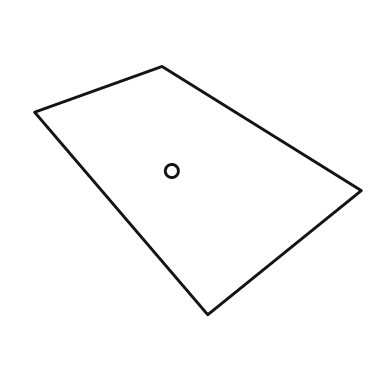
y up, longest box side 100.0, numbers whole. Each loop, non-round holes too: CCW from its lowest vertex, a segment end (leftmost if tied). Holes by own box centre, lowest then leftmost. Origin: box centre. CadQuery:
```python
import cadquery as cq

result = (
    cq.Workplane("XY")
    .moveTo(3.0, -38.0)
    .lineTo(50.0, 0.0)
    .lineTo(-11.0, 38.0)
    .lineTo(-50.0, 24.0)
    .close()
    .moveTo(-8.0, 6.0)
    .circle(2.0)
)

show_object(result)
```